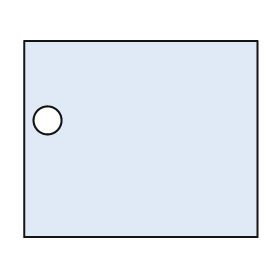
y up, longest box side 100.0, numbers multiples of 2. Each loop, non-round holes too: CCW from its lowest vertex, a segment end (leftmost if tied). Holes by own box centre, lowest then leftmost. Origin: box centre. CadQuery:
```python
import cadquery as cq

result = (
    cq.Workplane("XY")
    .moveTo(-50.0, -42.0)
    .lineTo(50.0, -42.0)
    .lineTo(50.0, 42.0)
    .lineTo(-50.0, 42.0)
    .close()
    .moveTo(-40.0, 8.0)
    .circle(6.0)
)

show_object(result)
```